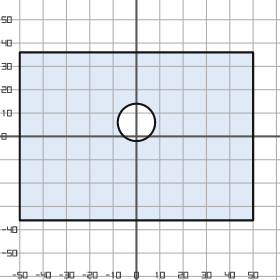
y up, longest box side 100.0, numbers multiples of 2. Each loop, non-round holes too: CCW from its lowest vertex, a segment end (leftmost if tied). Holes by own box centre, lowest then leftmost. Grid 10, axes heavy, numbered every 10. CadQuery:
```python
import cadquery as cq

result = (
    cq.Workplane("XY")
    .moveTo(-50.0, -36.0)
    .lineTo(50.0, -36.0)
    .lineTo(50.0, 36.0)
    .lineTo(-50.0, 36.0)
    .close()
    .moveTo(0.0, 6.0)
    .circle(8.0)
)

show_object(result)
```